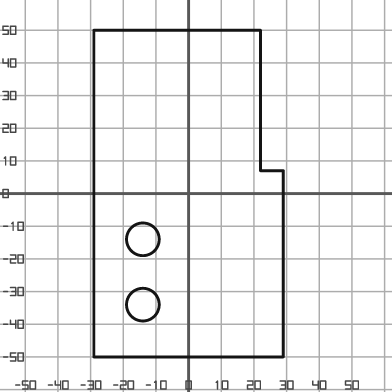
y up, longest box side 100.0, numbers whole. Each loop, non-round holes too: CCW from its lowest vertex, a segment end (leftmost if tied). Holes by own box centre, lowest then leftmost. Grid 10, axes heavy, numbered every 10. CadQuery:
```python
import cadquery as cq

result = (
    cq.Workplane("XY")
    .moveTo(-29.0, -50.0)
    .lineTo(29.0, -50.0)
    .lineTo(29.0, 7.0)
    .lineTo(22.0, 7.0)
    .lineTo(22.0, 50.0)
    .lineTo(-29.0, 50.0)
    .close()
    .moveTo(-14.0, -34.0)
    .circle(5.0)
    .moveTo(-14.0, -14.0)
    .circle(5.0)
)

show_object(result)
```